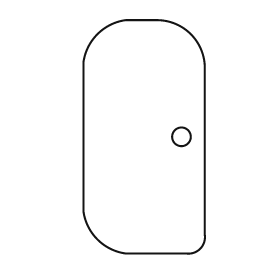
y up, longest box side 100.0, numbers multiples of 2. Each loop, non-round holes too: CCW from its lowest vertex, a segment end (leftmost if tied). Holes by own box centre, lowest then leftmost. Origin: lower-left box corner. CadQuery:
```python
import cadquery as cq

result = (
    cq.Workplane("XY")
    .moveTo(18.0, 0.0)
    .lineTo(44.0, 0.0)
    .threePointArc((50.0, 2.0), (52.0, 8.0))
    .lineTo(52.0, 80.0)
    .threePointArc((46.0, 94.0), (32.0, 100.0))
    .lineTo(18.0, 100.0)
    .threePointArc((6.0, 94.0), (0.0, 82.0))
    .lineTo(0.0, 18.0)
    .threePointArc((6.0, 6.0), (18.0, 0.0))
    .close()
    .moveTo(42.0, 50.0)
    .circle(4.0)
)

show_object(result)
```